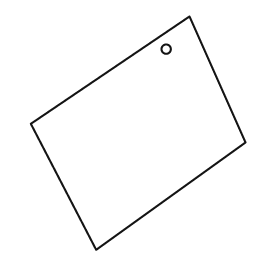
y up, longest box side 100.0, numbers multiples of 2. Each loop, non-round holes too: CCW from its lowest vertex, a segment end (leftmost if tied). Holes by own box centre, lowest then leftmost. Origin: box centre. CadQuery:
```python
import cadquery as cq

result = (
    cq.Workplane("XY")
    .moveTo(-18.0, -50.0)
    .lineTo(46.0, -4.0)
    .lineTo(22.0, 50.0)
    .lineTo(-46.0, 4.0)
    .close()
    .moveTo(12.0, 36.0)
    .circle(2.0)
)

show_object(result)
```